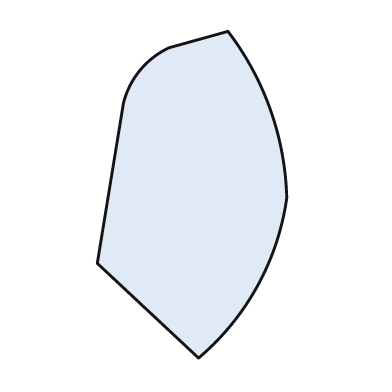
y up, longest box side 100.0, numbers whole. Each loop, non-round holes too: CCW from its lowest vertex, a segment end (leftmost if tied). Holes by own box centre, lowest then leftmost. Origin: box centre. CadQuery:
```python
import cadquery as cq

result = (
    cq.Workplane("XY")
    .moveTo(2.0, -50.0)
    .threePointArc((20.0, -28.0), (29.0, -1.0))
    .threePointArc((24.0, 26.0), (11.0, 50.0))
    .lineTo(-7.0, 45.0)
    .threePointArc((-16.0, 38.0), (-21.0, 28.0))
    .lineTo(-29.0, -21.0)
    .close()
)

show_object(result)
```